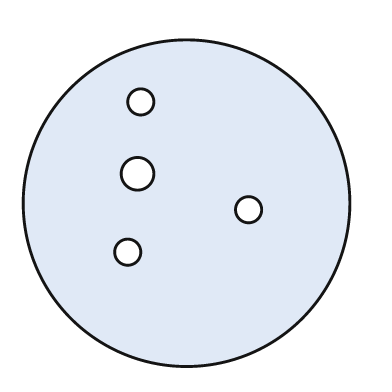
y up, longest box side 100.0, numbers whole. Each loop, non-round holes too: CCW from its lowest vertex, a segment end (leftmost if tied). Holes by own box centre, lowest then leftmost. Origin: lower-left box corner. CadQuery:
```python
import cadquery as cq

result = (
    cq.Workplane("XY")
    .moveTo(50.0, 50.0)
    .circle(50.0)
    .moveTo(32.0, 35.0)
    .circle(4.0)
    .moveTo(69.0, 48.0)
    .circle(4.0)
    .moveTo(35.0, 59.0)
    .circle(5.0)
    .moveTo(36.0, 81.0)
    .circle(4.0)
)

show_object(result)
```